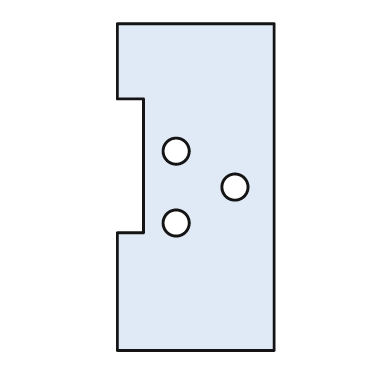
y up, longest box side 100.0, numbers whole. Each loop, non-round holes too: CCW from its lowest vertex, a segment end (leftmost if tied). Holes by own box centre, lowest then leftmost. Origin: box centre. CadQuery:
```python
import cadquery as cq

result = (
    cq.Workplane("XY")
    .moveTo(-24.0, -50.0)
    .lineTo(24.0, -50.0)
    .lineTo(24.0, 50.0)
    .lineTo(-24.0, 50.0)
    .lineTo(-24.0, 27.0)
    .lineTo(-16.0, 27.0)
    .lineTo(-16.0, -14.0)
    .lineTo(-24.0, -14.0)
    .close()
    .moveTo(-6.0, -11.0)
    .circle(4.0)
    .moveTo(12.0, 0.0)
    .circle(4.0)
    .moveTo(-6.0, 11.0)
    .circle(4.0)
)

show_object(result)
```